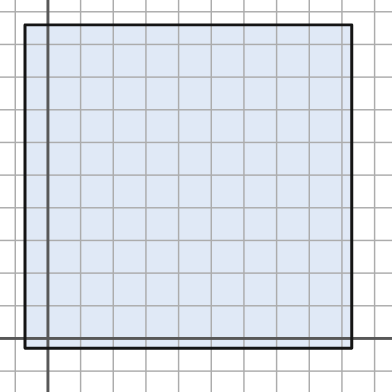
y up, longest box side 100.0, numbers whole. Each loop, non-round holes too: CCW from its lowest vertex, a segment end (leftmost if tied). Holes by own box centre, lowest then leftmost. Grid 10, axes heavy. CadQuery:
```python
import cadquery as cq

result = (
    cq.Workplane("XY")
    .moveTo(-7.0, -3.0)
    .lineTo(93.0, -3.0)
    .lineTo(93.0, 96.0)
    .lineTo(-7.0, 96.0)
    .close()
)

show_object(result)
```